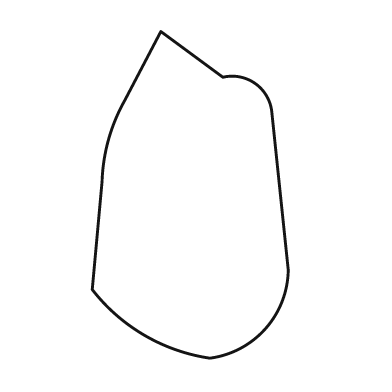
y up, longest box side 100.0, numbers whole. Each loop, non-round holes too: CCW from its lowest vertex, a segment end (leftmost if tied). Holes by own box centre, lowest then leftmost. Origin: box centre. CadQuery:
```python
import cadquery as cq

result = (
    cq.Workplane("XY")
    .moveTo(6.0, -50.0)
    .threePointArc((23.0, -41.0), (30.0, -23.0))
    .lineTo(25.0, 25.0)
    .threePointArc((20.0, 34.0), (10.0, 36.0))
    .lineTo(-9.0, 50.0)
    .lineTo(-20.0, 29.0)
    .threePointArc((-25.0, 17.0), (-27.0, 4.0))
    .lineTo(-30.0, -29.0)
    .threePointArc((-14.0, -43.0), (6.0, -50.0))
    .close()
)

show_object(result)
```